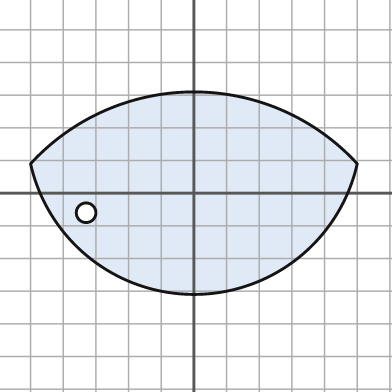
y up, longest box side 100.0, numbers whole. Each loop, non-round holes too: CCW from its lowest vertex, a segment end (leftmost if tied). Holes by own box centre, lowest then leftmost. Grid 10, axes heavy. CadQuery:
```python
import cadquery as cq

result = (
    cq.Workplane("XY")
    .moveTo(-50.0, 9.0)
    .threePointArc((0.0, -31.0), (50.0, 9.0))
    .threePointArc((0.0, 31.0), (-50.0, 9.0))
    .close()
    .moveTo(-33.0, -6.0)
    .circle(3.0)
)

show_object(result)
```